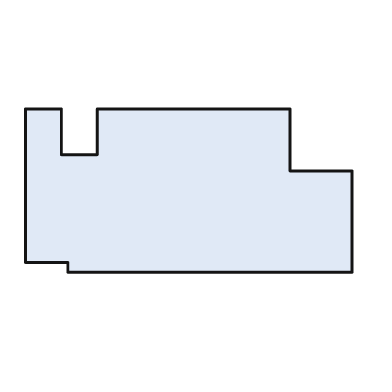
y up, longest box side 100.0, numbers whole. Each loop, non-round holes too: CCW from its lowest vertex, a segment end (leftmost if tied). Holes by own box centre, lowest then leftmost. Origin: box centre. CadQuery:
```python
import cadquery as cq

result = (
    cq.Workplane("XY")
    .moveTo(-37.0, -25.0)
    .lineTo(50.0, -25.0)
    .lineTo(50.0, 6.0)
    .lineTo(31.0, 6.0)
    .lineTo(31.0, 25.0)
    .lineTo(-28.0, 25.0)
    .lineTo(-28.0, 11.0)
    .lineTo(-39.0, 11.0)
    .lineTo(-39.0, 25.0)
    .lineTo(-50.0, 25.0)
    .lineTo(-50.0, -22.0)
    .lineTo(-37.0, -22.0)
    .close()
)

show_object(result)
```